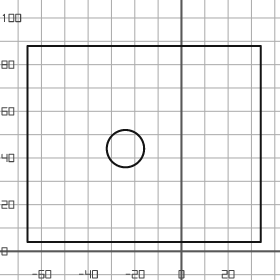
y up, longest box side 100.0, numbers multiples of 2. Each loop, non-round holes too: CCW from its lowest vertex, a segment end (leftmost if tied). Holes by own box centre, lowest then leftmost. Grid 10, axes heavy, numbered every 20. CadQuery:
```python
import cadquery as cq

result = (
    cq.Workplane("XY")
    .moveTo(-66.0, 4.0)
    .lineTo(34.0, 4.0)
    .lineTo(34.0, 88.0)
    .lineTo(-66.0, 88.0)
    .close()
    .moveTo(-24.0, 44.0)
    .circle(8.0)
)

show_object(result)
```